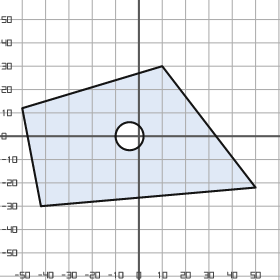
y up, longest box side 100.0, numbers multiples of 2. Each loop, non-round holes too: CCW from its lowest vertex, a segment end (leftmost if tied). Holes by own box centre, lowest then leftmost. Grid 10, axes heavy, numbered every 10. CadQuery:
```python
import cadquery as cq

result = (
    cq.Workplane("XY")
    .moveTo(-42.0, -30.0)
    .lineTo(50.0, -22.0)
    .lineTo(10.0, 30.0)
    .lineTo(-50.0, 12.0)
    .close()
    .moveTo(-4.0, 0.0)
    .circle(6.0)
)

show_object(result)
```